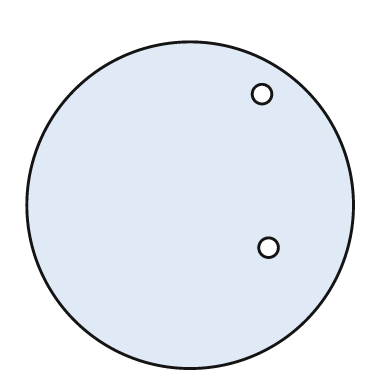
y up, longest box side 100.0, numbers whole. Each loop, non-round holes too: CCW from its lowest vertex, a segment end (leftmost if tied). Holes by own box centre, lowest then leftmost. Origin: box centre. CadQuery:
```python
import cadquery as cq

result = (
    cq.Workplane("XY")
    .moveTo(0.0, 0.0)
    .circle(50.0)
    .moveTo(24.0, -13.0)
    .circle(3.0)
    .moveTo(22.0, 34.0)
    .circle(3.0)
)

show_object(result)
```